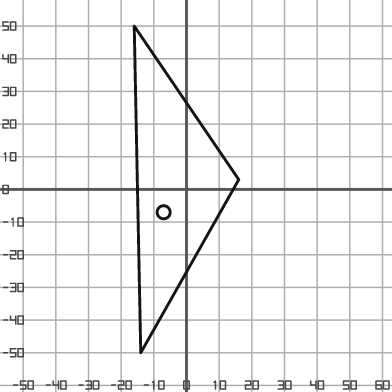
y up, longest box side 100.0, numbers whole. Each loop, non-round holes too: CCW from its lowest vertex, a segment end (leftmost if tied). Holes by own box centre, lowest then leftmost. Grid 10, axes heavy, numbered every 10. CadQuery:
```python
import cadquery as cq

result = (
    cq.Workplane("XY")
    .moveTo(-14.0, -50.0)
    .lineTo(16.0, 3.0)
    .lineTo(-16.0, 50.0)
    .close()
    .moveTo(-7.0, -7.0)
    .circle(2.0)
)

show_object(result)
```